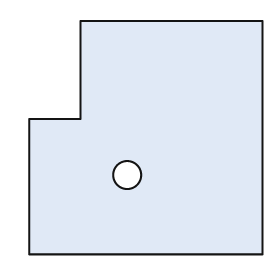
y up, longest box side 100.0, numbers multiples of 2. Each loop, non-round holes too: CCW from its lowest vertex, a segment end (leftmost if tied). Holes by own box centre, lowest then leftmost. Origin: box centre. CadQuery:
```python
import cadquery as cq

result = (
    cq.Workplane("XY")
    .moveTo(-50.0, -50.0)
    .lineTo(50.0, -50.0)
    .lineTo(50.0, 50.0)
    .lineTo(-28.0, 50.0)
    .lineTo(-28.0, 8.0)
    .lineTo(-50.0, 8.0)
    .close()
    .moveTo(-8.0, -16.0)
    .circle(6.0)
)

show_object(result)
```